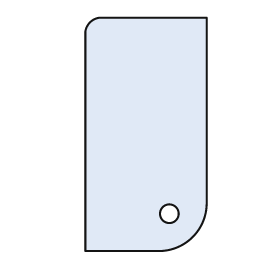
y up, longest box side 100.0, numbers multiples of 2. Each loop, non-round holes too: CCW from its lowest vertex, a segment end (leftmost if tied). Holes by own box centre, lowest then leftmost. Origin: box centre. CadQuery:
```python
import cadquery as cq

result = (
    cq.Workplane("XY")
    .moveTo(-26.0, -50.0)
    .lineTo(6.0, -50.0)
    .threePointArc((20.0, -44.0), (26.0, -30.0))
    .lineTo(26.0, 50.0)
    .lineTo(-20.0, 50.0)
    .threePointArc((-24.0, 48.0), (-26.0, 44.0))
    .close()
    .moveTo(10.0, -34.0)
    .circle(4.0)
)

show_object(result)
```